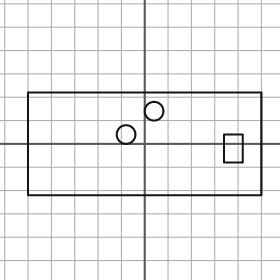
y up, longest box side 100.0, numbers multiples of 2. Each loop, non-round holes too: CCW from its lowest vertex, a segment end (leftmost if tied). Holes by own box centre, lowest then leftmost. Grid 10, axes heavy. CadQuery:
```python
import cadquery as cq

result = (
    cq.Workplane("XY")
    .moveTo(-50.0, -22.0)
    .lineTo(50.0, -22.0)
    .lineTo(50.0, 22.0)
    .lineTo(-50.0, 22.0)
    .close()
    .moveTo(34.0, -8.0)
    .lineTo(42.0, -8.0)
    .lineTo(42.0, 4.0)
    .lineTo(34.0, 4.0)
    .close()
    .moveTo(-8.0, 4.0)
    .circle(4.0)
    .moveTo(4.0, 14.0)
    .circle(4.0)
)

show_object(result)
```